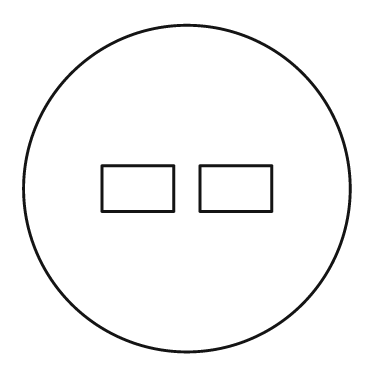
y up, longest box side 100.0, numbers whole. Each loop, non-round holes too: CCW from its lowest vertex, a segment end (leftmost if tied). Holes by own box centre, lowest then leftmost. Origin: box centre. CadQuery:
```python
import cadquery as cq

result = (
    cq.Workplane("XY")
    .moveTo(0.0, 0.0)
    .circle(50.0)
    .moveTo(-26.0, -7.0)
    .lineTo(-4.0, -7.0)
    .lineTo(-4.0, 7.0)
    .lineTo(-26.0, 7.0)
    .close()
    .moveTo(4.0, -7.0)
    .lineTo(26.0, -7.0)
    .lineTo(26.0, 7.0)
    .lineTo(4.0, 7.0)
    .close()
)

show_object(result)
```